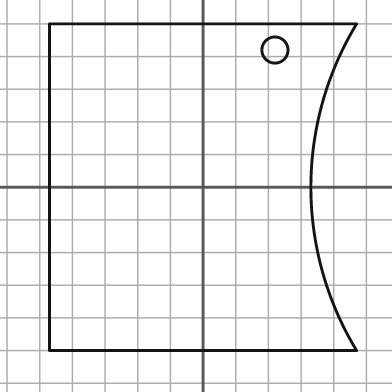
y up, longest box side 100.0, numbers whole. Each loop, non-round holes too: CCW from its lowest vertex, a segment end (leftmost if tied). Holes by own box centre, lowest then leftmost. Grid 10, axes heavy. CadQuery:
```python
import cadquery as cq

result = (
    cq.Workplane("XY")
    .moveTo(-47.0, -50.0)
    .lineTo(47.0, -50.0)
    .threePointArc((33.0, 0.0), (47.0, 50.0))
    .lineTo(-47.0, 50.0)
    .close()
    .moveTo(22.0, 42.0)
    .circle(4.0)
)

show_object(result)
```